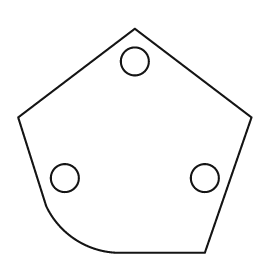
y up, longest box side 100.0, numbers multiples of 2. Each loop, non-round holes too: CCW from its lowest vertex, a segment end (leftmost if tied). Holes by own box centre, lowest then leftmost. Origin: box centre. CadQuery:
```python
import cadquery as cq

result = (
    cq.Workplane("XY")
    .moveTo(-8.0, -48.0)
    .lineTo(30.0, -48.0)
    .lineTo(50.0, 10.0)
    .lineTo(0.0, 48.0)
    .lineTo(-50.0, 10.0)
    .lineTo(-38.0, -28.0)
    .threePointArc((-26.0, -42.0), (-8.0, -48.0))
    .close()
    .moveTo(-30.0, -16.0)
    .circle(6.0)
    .moveTo(30.0, -16.0)
    .circle(6.0)
    .moveTo(0.0, 34.0)
    .circle(6.0)
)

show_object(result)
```